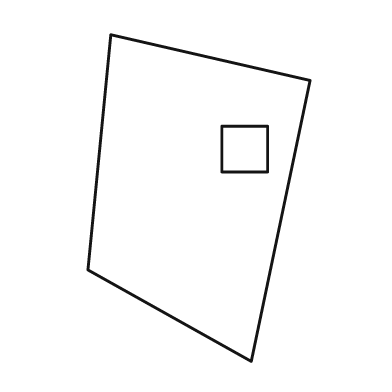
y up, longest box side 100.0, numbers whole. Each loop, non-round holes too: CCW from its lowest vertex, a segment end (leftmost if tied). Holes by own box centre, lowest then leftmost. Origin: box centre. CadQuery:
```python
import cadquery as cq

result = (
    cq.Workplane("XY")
    .moveTo(16.0, -50.0)
    .lineTo(34.0, 36.0)
    .lineTo(-27.0, 50.0)
    .lineTo(-34.0, -22.0)
    .close()
    .moveTo(7.0, 8.0)
    .lineTo(21.0, 8.0)
    .lineTo(21.0, 22.0)
    .lineTo(7.0, 22.0)
    .close()
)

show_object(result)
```